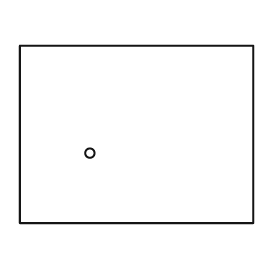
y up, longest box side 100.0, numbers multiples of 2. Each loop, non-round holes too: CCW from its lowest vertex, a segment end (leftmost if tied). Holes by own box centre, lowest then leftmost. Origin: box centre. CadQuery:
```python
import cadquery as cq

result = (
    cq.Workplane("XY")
    .moveTo(-50.0, -38.0)
    .lineTo(50.0, -38.0)
    .lineTo(50.0, 38.0)
    .lineTo(-50.0, 38.0)
    .close()
    .moveTo(-20.0, -8.0)
    .circle(2.0)
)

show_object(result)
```